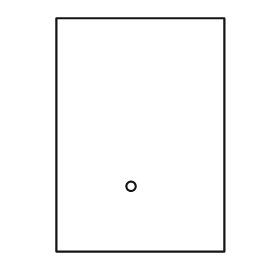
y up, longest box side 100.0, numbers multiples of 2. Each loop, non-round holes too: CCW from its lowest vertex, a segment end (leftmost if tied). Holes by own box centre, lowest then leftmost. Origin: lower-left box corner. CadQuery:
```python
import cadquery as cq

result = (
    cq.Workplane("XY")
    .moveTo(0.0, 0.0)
    .lineTo(72.0, 0.0)
    .lineTo(72.0, 100.0)
    .lineTo(0.0, 100.0)
    .close()
    .moveTo(32.0, 28.0)
    .circle(2.0)
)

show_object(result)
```